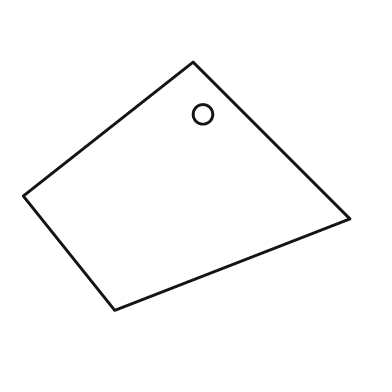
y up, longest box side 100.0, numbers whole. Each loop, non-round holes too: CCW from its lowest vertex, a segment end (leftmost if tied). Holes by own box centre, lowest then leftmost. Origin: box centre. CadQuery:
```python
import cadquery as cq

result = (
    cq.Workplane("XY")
    .moveTo(-22.0, -38.0)
    .lineTo(50.0, -10.0)
    .lineTo(2.0, 38.0)
    .lineTo(-50.0, -3.0)
    .close()
    .moveTo(5.0, 22.0)
    .circle(3.0)
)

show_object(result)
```